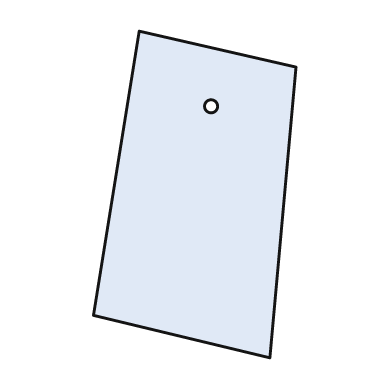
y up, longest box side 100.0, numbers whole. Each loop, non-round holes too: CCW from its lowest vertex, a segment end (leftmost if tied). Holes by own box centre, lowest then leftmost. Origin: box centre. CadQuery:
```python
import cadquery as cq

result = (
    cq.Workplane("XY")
    .moveTo(23.0, -50.0)
    .lineTo(31.0, 39.0)
    .lineTo(-17.0, 50.0)
    .lineTo(-31.0, -37.0)
    .close()
    .moveTo(5.0, 27.0)
    .circle(2.0)
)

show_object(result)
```